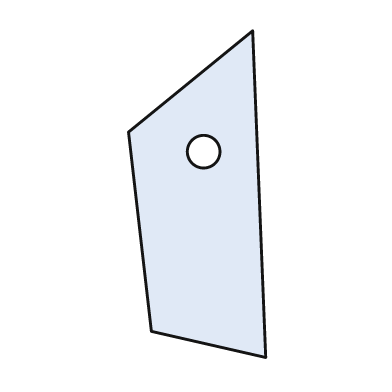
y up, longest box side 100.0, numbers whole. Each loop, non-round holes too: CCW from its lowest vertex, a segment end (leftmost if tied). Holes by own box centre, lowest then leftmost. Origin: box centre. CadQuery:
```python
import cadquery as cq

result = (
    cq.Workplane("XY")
    .moveTo(21.0, -50.0)
    .lineTo(17.0, 50.0)
    .lineTo(-21.0, 19.0)
    .lineTo(-14.0, -42.0)
    .close()
    .moveTo(2.0, 13.0)
    .circle(5.0)
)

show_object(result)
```